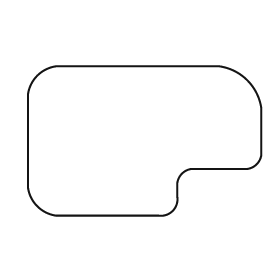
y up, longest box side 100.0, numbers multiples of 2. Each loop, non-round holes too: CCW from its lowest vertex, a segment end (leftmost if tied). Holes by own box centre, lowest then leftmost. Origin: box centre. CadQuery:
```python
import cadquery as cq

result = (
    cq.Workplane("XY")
    .moveTo(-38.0, -32.0)
    .lineTo(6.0, -32.0)
    .threePointArc((12.0, -30.0), (14.0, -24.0))
    .lineTo(14.0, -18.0)
    .threePointArc((16.0, -14.0), (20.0, -12.0))
    .lineTo(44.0, -12.0)
    .threePointArc((48.0, -10.0), (50.0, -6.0))
    .lineTo(50.0, 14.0)
    .threePointArc((44.0, 26.0), (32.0, 32.0))
    .lineTo(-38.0, 32.0)
    .threePointArc((-46.0, 28.0), (-50.0, 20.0))
    .lineTo(-50.0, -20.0)
    .threePointArc((-46.0, -28.0), (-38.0, -32.0))
    .close()
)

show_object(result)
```